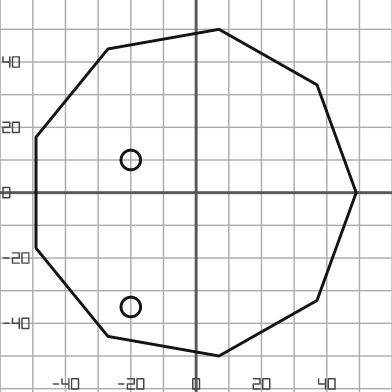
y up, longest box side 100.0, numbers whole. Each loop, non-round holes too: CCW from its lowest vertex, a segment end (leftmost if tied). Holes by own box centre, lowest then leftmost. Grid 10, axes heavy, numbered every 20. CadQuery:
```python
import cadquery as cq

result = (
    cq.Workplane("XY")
    .moveTo(7.0, -50.0)
    .lineTo(37.0, -33.0)
    .lineTo(49.0, 0.0)
    .lineTo(37.0, 33.0)
    .lineTo(7.0, 50.0)
    .lineTo(-27.0, 44.0)
    .lineTo(-49.0, 17.0)
    .lineTo(-49.0, -17.0)
    .lineTo(-27.0, -44.0)
    .close()
    .moveTo(-20.0, -35.0)
    .circle(3.0)
    .moveTo(-20.0, 10.0)
    .circle(3.0)
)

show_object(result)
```